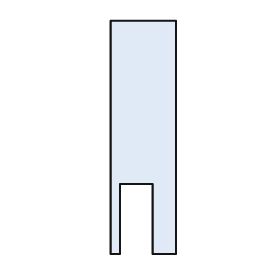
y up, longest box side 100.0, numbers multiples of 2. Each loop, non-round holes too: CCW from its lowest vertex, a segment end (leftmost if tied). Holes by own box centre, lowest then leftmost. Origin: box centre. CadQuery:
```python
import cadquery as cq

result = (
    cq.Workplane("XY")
    .moveTo(-14.0, -50.0)
    .lineTo(-10.0, -50.0)
    .lineTo(-10.0, -20.0)
    .lineTo(4.0, -20.0)
    .lineTo(4.0, -50.0)
    .lineTo(14.0, -50.0)
    .lineTo(14.0, 50.0)
    .lineTo(-14.0, 50.0)
    .close()
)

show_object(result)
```